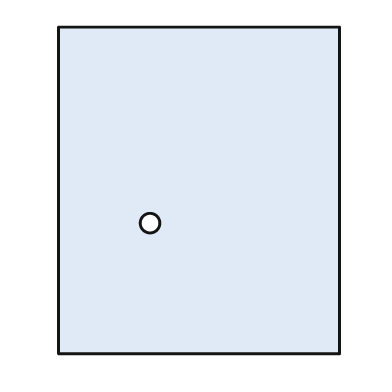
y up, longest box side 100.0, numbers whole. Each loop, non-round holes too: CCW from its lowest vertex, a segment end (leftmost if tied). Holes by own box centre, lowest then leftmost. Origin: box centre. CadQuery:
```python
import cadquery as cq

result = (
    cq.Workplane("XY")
    .moveTo(-43.0, -50.0)
    .lineTo(43.0, -50.0)
    .lineTo(43.0, 50.0)
    .lineTo(-43.0, 50.0)
    .close()
    .moveTo(-15.0, -10.0)
    .circle(3.0)
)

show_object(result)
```